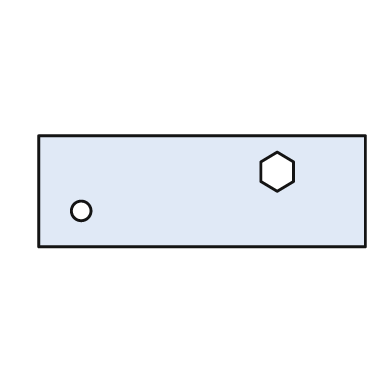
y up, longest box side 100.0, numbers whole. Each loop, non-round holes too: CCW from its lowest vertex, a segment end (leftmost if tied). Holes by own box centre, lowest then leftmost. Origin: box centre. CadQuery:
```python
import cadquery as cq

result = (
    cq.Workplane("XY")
    .moveTo(-50.0, -17.0)
    .lineTo(50.0, -17.0)
    .lineTo(50.0, 17.0)
    .lineTo(-50.0, 17.0)
    .close()
    .moveTo(-37.0, -6.0)
    .circle(3.0)
    .moveTo(23.0, 0.0)
    .lineTo(28.0, 3.0)
    .lineTo(28.0, 9.0)
    .lineTo(23.0, 12.0)
    .lineTo(18.0, 9.0)
    .lineTo(18.0, 3.0)
    .close()
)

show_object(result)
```